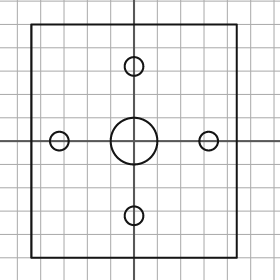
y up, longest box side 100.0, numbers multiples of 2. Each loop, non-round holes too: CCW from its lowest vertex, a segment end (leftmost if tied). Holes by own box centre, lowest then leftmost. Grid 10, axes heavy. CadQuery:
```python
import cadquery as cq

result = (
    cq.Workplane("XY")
    .moveTo(-44.0, -50.0)
    .lineTo(44.0, -50.0)
    .lineTo(44.0, 50.0)
    .lineTo(-44.0, 50.0)
    .close()
    .moveTo(0.0, -32.0)
    .circle(4.0)
    .moveTo(-32.0, 0.0)
    .circle(4.0)
    .moveTo(0.0, 0.0)
    .circle(10.0)
    .moveTo(32.0, 0.0)
    .circle(4.0)
    .moveTo(0.0, 32.0)
    .circle(4.0)
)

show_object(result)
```